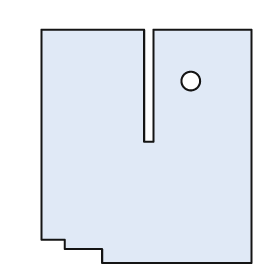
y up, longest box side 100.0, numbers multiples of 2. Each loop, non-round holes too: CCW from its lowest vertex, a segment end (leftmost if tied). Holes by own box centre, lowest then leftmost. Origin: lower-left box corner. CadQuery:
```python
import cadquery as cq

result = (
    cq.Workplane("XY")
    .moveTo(26.0, 0.0)
    .lineTo(90.0, 0.0)
    .lineTo(90.0, 100.0)
    .lineTo(48.0, 100.0)
    .lineTo(48.0, 52.0)
    .lineTo(44.0, 52.0)
    .lineTo(44.0, 100.0)
    .lineTo(0.0, 100.0)
    .lineTo(0.0, 10.0)
    .lineTo(10.0, 10.0)
    .lineTo(10.0, 6.0)
    .lineTo(26.0, 6.0)
    .close()
    .moveTo(64.0, 78.0)
    .circle(4.0)
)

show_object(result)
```